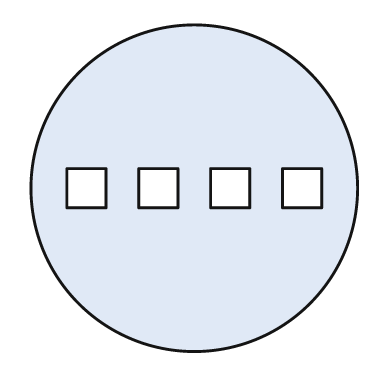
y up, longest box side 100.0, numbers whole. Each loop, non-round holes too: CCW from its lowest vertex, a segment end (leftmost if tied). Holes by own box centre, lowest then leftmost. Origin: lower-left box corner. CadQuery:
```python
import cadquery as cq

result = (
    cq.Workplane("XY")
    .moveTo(50.0, 50.0)
    .circle(50.0)
    .moveTo(11.0, 44.0)
    .lineTo(23.0, 44.0)
    .lineTo(23.0, 56.0)
    .lineTo(11.0, 56.0)
    .close()
    .moveTo(33.0, 44.0)
    .lineTo(45.0, 44.0)
    .lineTo(45.0, 56.0)
    .lineTo(33.0, 56.0)
    .close()
    .moveTo(55.0, 44.0)
    .lineTo(67.0, 44.0)
    .lineTo(67.0, 56.0)
    .lineTo(55.0, 56.0)
    .close()
    .moveTo(77.0, 44.0)
    .lineTo(89.0, 44.0)
    .lineTo(89.0, 56.0)
    .lineTo(77.0, 56.0)
    .close()
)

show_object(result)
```